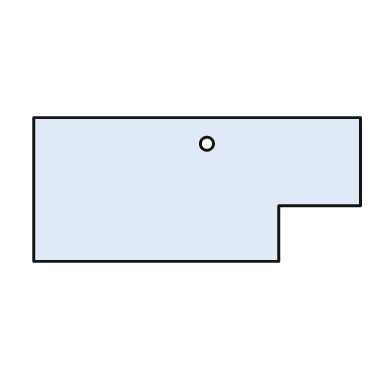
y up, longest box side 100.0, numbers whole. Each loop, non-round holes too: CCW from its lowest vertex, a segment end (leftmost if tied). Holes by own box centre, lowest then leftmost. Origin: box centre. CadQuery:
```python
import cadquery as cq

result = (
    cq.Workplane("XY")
    .moveTo(-50.0, -22.0)
    .lineTo(25.0, -22.0)
    .lineTo(25.0, -5.0)
    .lineTo(50.0, -5.0)
    .lineTo(50.0, 22.0)
    .lineTo(-50.0, 22.0)
    .close()
    .moveTo(3.0, 14.0)
    .circle(2.0)
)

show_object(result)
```